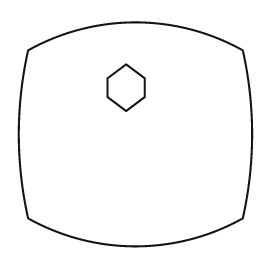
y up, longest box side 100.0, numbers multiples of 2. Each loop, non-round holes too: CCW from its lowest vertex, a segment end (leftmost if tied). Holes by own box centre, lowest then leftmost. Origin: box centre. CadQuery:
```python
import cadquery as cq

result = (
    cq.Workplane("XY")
    .moveTo(-46.0, -36.0)
    .threePointArc((0.0, -48.0), (46.0, -36.0))
    .threePointArc((50.0, 0.0), (46.0, 36.0))
    .threePointArc((0.0, 48.0), (-46.0, 36.0))
    .threePointArc((-50.0, 0.0), (-46.0, -36.0))
    .close()
    .moveTo(-4.0, 10.0)
    .lineTo(4.0, 16.0)
    .lineTo(4.0, 24.0)
    .lineTo(-4.0, 30.0)
    .lineTo(-12.0, 24.0)
    .lineTo(-12.0, 16.0)
    .close()
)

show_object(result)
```